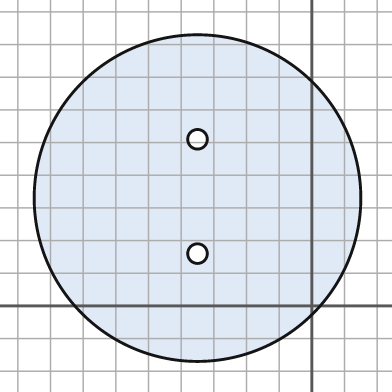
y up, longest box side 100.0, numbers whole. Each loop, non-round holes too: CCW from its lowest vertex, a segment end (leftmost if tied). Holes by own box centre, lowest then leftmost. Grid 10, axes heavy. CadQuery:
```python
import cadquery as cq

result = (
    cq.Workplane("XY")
    .moveTo(-35.0, 33.0)
    .circle(50.0)
    .moveTo(-35.0, 16.0)
    .circle(3.0)
    .moveTo(-35.0, 51.0)
    .circle(3.0)
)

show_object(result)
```